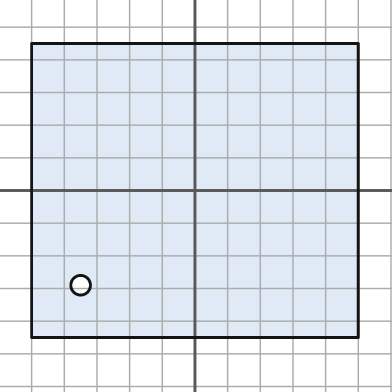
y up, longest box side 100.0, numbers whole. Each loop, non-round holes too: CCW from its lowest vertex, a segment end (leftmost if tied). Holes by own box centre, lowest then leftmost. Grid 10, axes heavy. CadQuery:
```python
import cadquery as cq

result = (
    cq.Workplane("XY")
    .moveTo(-50.0, -45.0)
    .lineTo(50.0, -45.0)
    .lineTo(50.0, 45.0)
    .lineTo(-50.0, 45.0)
    .close()
    .moveTo(-35.0, -29.0)
    .circle(3.0)
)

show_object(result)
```